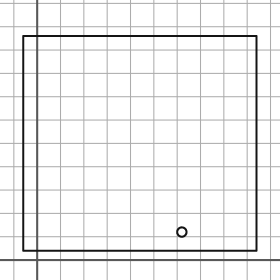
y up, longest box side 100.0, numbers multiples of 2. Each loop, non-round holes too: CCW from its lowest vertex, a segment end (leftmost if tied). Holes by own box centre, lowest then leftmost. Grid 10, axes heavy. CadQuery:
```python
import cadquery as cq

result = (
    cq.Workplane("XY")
    .moveTo(-6.0, 4.0)
    .lineTo(94.0, 4.0)
    .lineTo(94.0, 96.0)
    .lineTo(-6.0, 96.0)
    .close()
    .moveTo(62.0, 12.0)
    .circle(2.0)
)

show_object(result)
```